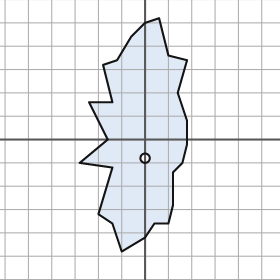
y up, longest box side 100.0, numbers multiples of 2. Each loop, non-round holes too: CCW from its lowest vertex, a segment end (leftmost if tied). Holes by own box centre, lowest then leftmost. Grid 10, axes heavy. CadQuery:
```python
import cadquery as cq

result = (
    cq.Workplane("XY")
    .moveTo(-10.0, -48.0)
    .lineTo(0.0, -42.0)
    .lineTo(4.0, -36.0)
    .lineTo(10.0, -36.0)
    .lineTo(12.0, -28.0)
    .lineTo(12.0, -14.0)
    .lineTo(16.0, -10.0)
    .lineTo(18.0, -2.0)
    .lineTo(18.0, 8.0)
    .lineTo(14.0, 20.0)
    .lineTo(18.0, 34.0)
    .lineTo(10.0, 36.0)
    .lineTo(6.0, 52.0)
    .lineTo(0.0, 50.0)
    .lineTo(-6.0, 44.0)
    .lineTo(-12.0, 34.0)
    .lineTo(-18.0, 32.0)
    .lineTo(-14.0, 16.0)
    .lineTo(-24.0, 16.0)
    .lineTo(-16.0, 0.0)
    .lineTo(-28.0, -10.0)
    .lineTo(-14.0, -12.0)
    .lineTo(-20.0, -32.0)
    .lineTo(-14.0, -36.0)
    .close()
    .moveTo(0.0, -8.0)
    .circle(2.0)
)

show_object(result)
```